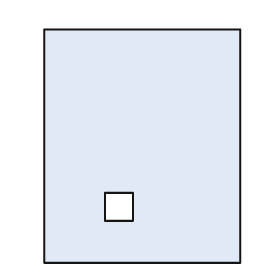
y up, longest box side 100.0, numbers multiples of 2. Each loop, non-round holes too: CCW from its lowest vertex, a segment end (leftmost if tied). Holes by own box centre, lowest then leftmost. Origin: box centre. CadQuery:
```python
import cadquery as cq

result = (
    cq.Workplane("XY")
    .moveTo(-42.0, -50.0)
    .lineTo(42.0, -50.0)
    .lineTo(42.0, 50.0)
    .lineTo(-42.0, 50.0)
    .close()
    .moveTo(-16.0, -32.0)
    .lineTo(-4.0, -32.0)
    .lineTo(-4.0, -20.0)
    .lineTo(-16.0, -20.0)
    .close()
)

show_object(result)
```